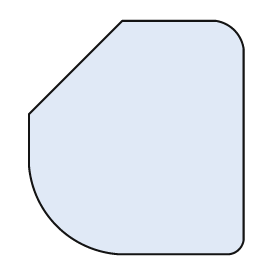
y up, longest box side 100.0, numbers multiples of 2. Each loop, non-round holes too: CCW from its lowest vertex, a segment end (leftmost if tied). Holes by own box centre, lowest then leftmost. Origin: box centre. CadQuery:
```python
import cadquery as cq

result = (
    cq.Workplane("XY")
    .moveTo(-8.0, -50.0)
    .lineTo(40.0, -50.0)
    .threePointArc((44.0, -48.0), (46.0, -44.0))
    .lineTo(46.0, 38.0)
    .threePointArc((42.0, 46.0), (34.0, 50.0))
    .lineTo(-6.0, 50.0)
    .lineTo(-46.0, 10.0)
    .lineTo(-46.0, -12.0)
    .threePointArc((-34.0, -38.0), (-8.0, -50.0))
    .close()
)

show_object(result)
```